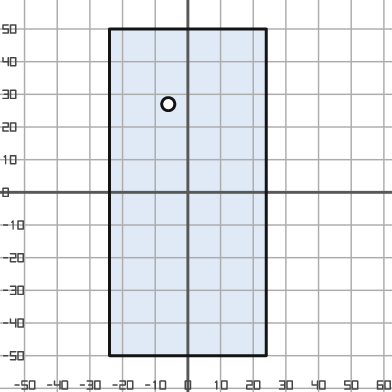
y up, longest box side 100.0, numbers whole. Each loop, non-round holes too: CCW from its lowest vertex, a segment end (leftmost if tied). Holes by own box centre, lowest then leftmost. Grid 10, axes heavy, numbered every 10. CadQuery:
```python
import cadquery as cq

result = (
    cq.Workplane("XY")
    .moveTo(-24.0, -50.0)
    .lineTo(24.0, -50.0)
    .lineTo(24.0, 50.0)
    .lineTo(-24.0, 50.0)
    .close()
    .moveTo(-6.0, 27.0)
    .circle(2.0)
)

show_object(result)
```